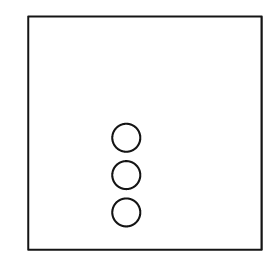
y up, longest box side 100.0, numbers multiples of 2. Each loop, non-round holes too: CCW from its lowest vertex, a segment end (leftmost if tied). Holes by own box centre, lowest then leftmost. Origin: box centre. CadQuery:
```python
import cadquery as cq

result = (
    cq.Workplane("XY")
    .moveTo(-50.0, -50.0)
    .lineTo(50.0, -50.0)
    .lineTo(50.0, 50.0)
    .lineTo(-50.0, 50.0)
    .close()
    .moveTo(-8.0, -34.0)
    .circle(6.0)
    .moveTo(-8.0, -18.0)
    .circle(6.0)
    .moveTo(-8.0, -2.0)
    .circle(6.0)
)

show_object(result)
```